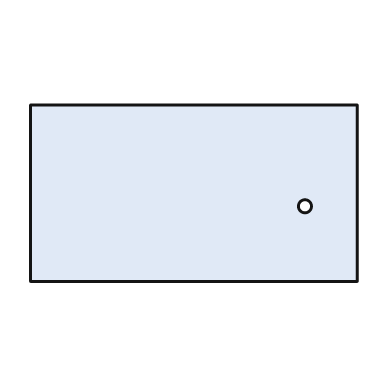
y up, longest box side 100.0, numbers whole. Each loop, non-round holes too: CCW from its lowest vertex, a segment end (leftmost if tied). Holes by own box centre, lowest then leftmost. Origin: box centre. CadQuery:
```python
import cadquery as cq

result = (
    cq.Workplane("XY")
    .moveTo(-50.0, -27.0)
    .lineTo(50.0, -27.0)
    .lineTo(50.0, 27.0)
    .lineTo(-50.0, 27.0)
    .close()
    .moveTo(34.0, -4.0)
    .circle(2.0)
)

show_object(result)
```